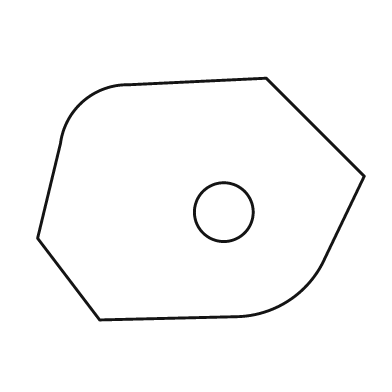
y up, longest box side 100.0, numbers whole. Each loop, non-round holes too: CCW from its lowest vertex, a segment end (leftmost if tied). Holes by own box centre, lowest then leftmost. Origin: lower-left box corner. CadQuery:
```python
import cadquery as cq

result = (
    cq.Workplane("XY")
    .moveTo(19.0, 0.0)
    .lineTo(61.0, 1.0)
    .threePointArc((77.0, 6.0), (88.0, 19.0))
    .lineTo(100.0, 44.0)
    .lineTo(70.0, 74.0)
    .lineTo(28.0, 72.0)
    .threePointArc((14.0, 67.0), (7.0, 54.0))
    .lineTo(0.0, 25.0)
    .close()
    .moveTo(57.0, 33.0)
    .circle(9.0)
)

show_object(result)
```